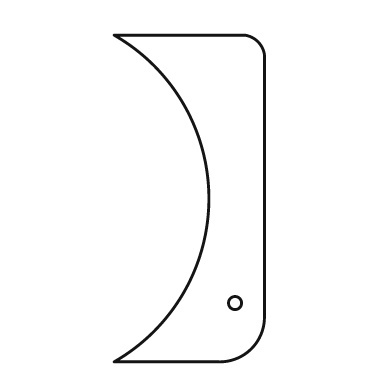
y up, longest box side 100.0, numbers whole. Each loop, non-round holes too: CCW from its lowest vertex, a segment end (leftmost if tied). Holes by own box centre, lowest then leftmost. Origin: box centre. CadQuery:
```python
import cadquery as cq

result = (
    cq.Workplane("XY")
    .moveTo(-23.0, -50.0)
    .lineTo(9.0, -50.0)
    .threePointArc((19.0, -46.0), (23.0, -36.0))
    .lineTo(23.0, 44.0)
    .threePointArc((21.0, 48.0), (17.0, 50.0))
    .lineTo(-23.0, 50.0)
    .threePointArc((6.0, 0.0), (-23.0, -50.0))
    .close()
    .moveTo(14.0, -32.0)
    .circle(2.0)
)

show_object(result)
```